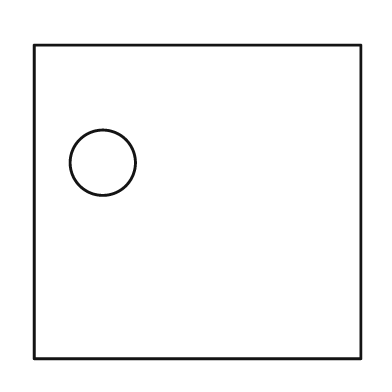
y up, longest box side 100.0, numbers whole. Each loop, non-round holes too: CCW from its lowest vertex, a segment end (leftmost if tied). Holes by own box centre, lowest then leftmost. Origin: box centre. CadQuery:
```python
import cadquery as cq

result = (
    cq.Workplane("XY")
    .moveTo(-50.0, -48.0)
    .lineTo(50.0, -48.0)
    .lineTo(50.0, 48.0)
    .lineTo(-50.0, 48.0)
    .close()
    .moveTo(-29.0, 12.0)
    .circle(10.0)
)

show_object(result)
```